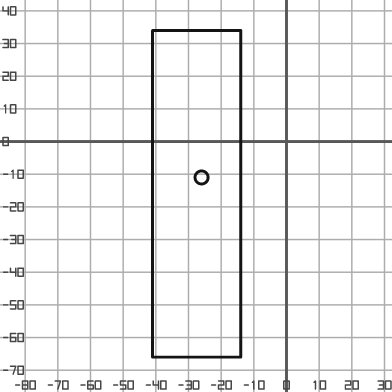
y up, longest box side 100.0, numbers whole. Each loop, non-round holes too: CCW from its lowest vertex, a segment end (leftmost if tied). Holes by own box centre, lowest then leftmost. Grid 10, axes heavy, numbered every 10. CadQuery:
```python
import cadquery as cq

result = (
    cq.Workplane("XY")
    .moveTo(-41.0, -66.0)
    .lineTo(-14.0, -66.0)
    .lineTo(-14.0, 34.0)
    .lineTo(-41.0, 34.0)
    .close()
    .moveTo(-26.0, -11.0)
    .circle(2.0)
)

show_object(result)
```